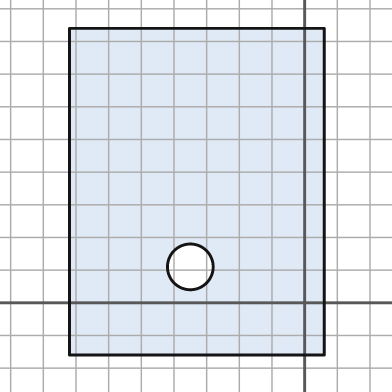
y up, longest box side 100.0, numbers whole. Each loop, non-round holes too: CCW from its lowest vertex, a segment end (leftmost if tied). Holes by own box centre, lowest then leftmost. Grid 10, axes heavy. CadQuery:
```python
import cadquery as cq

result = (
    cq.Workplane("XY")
    .moveTo(-72.0, -16.0)
    .lineTo(6.0, -16.0)
    .lineTo(6.0, 84.0)
    .lineTo(-72.0, 84.0)
    .close()
    .moveTo(-35.0, 11.0)
    .circle(7.0)
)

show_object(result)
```